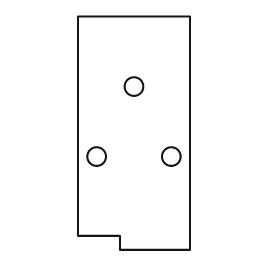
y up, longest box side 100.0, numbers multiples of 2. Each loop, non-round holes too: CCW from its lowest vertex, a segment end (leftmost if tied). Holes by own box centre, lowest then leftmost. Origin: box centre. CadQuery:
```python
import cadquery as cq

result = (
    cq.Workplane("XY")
    .moveTo(-6.0, -50.0)
    .lineTo(24.0, -50.0)
    .lineTo(24.0, 50.0)
    .lineTo(-24.0, 50.0)
    .lineTo(-24.0, -44.0)
    .lineTo(-6.0, -44.0)
    .close()
    .moveTo(-16.0, -10.0)
    .circle(4.0)
    .moveTo(16.0, -10.0)
    .circle(4.0)
    .moveTo(0.0, 20.0)
    .circle(4.0)
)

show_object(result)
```